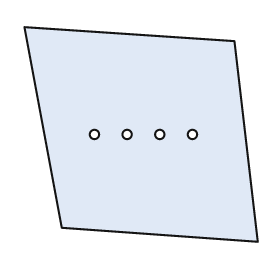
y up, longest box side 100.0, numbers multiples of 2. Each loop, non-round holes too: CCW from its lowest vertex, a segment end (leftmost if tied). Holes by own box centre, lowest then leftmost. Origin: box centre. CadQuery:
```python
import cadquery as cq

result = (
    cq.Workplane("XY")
    .moveTo(50.0, -46.0)
    .lineTo(40.0, 40.0)
    .lineTo(-50.0, 46.0)
    .lineTo(-34.0, -40.0)
    .close()
    .moveTo(-20.0, 0.0)
    .circle(2.0)
    .moveTo(-6.0, 0.0)
    .circle(2.0)
    .moveTo(8.0, 0.0)
    .circle(2.0)
    .moveTo(22.0, 0.0)
    .circle(2.0)
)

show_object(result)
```